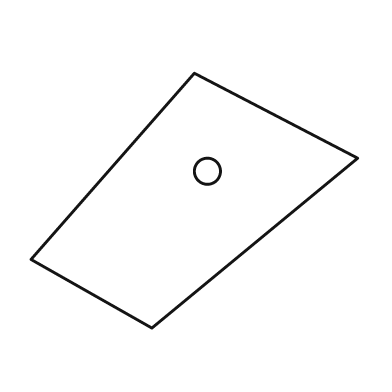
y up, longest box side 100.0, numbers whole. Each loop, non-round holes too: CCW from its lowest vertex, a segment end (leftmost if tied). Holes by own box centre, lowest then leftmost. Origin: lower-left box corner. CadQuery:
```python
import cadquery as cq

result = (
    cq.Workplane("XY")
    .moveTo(37.0, 0.0)
    .lineTo(100.0, 52.0)
    .lineTo(50.0, 78.0)
    .lineTo(0.0, 21.0)
    .close()
    .moveTo(54.0, 48.0)
    .circle(4.0)
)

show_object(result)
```